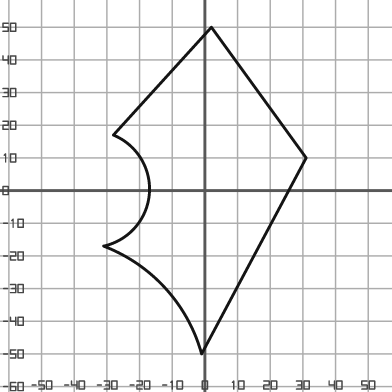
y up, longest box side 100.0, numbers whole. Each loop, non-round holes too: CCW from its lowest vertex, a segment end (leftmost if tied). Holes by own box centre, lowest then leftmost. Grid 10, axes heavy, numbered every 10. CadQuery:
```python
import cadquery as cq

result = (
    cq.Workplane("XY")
    .moveTo(-1.0, -50.0)
    .lineTo(31.0, 10.0)
    .lineTo(2.0, 50.0)
    .lineTo(-28.0, 17.0)
    .threePointArc((-17.0, -1.0), (-31.0, -17.0))
    .threePointArc((-12.0, -30.0), (-1.0, -50.0))
    .close()
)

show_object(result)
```